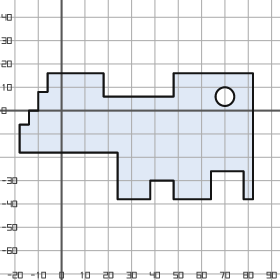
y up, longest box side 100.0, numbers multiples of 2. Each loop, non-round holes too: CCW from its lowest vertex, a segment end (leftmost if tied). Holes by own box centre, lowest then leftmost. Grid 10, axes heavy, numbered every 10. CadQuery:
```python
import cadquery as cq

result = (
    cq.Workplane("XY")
    .moveTo(24.0, -38.0)
    .lineTo(38.0, -38.0)
    .lineTo(38.0, -30.0)
    .lineTo(48.0, -30.0)
    .lineTo(48.0, -38.0)
    .lineTo(64.0, -38.0)
    .lineTo(64.0, -26.0)
    .lineTo(78.0, -26.0)
    .lineTo(78.0, -38.0)
    .lineTo(82.0, -38.0)
    .lineTo(82.0, 16.0)
    .lineTo(48.0, 16.0)
    .lineTo(48.0, 6.0)
    .lineTo(18.0, 6.0)
    .lineTo(18.0, 16.0)
    .lineTo(-6.0, 16.0)
    .lineTo(-6.0, 8.0)
    .lineTo(-10.0, 8.0)
    .lineTo(-10.0, 0.0)
    .lineTo(-14.0, 0.0)
    .lineTo(-14.0, -6.0)
    .lineTo(-18.0, -6.0)
    .lineTo(-18.0, -18.0)
    .lineTo(24.0, -18.0)
    .close()
    .moveTo(70.0, 6.0)
    .circle(4.0)
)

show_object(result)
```